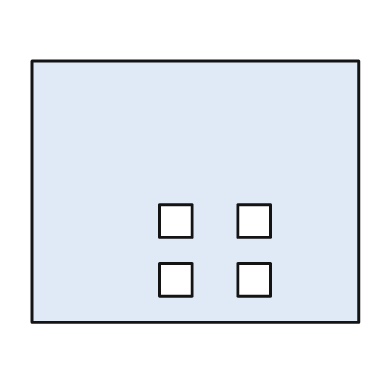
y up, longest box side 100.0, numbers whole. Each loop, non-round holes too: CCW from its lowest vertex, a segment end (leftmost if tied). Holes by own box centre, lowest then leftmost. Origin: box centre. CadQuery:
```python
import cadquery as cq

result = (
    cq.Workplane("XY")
    .moveTo(-50.0, -40.0)
    .lineTo(50.0, -40.0)
    .lineTo(50.0, 40.0)
    .lineTo(-50.0, 40.0)
    .close()
    .moveTo(-11.0, -32.0)
    .lineTo(-1.0, -32.0)
    .lineTo(-1.0, -22.0)
    .lineTo(-11.0, -22.0)
    .close()
    .moveTo(13.0, -32.0)
    .lineTo(23.0, -32.0)
    .lineTo(23.0, -22.0)
    .lineTo(13.0, -22.0)
    .close()
    .moveTo(-11.0, -14.0)
    .lineTo(-1.0, -14.0)
    .lineTo(-1.0, -4.0)
    .lineTo(-11.0, -4.0)
    .close()
    .moveTo(13.0, -14.0)
    .lineTo(23.0, -14.0)
    .lineTo(23.0, -4.0)
    .lineTo(13.0, -4.0)
    .close()
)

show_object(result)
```